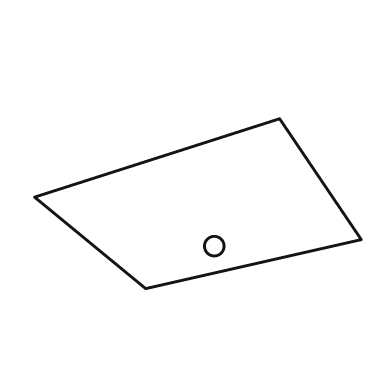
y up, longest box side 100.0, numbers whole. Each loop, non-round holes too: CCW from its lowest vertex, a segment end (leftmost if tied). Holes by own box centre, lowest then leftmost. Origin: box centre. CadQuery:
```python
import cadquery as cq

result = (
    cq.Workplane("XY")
    .moveTo(-16.0, -26.0)
    .lineTo(50.0, -11.0)
    .lineTo(25.0, 26.0)
    .lineTo(-50.0, 2.0)
    .close()
    .moveTo(5.0, -13.0)
    .circle(3.0)
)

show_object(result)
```